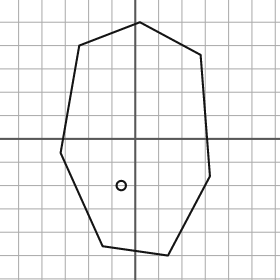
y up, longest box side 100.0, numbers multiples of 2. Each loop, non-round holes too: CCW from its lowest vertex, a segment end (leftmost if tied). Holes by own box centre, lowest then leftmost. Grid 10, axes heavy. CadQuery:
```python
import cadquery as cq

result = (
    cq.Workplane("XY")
    .moveTo(14.0, -50.0)
    .lineTo(32.0, -16.0)
    .lineTo(28.0, 36.0)
    .lineTo(2.0, 50.0)
    .lineTo(-24.0, 40.0)
    .lineTo(-32.0, -6.0)
    .lineTo(-14.0, -46.0)
    .close()
    .moveTo(-6.0, -20.0)
    .circle(2.0)
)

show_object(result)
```